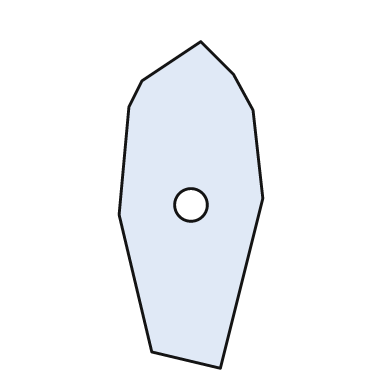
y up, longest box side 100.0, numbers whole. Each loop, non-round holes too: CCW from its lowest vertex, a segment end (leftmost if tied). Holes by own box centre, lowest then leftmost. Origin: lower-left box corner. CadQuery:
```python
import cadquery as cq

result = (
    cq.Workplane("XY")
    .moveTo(31.0, 0.0)
    .lineTo(44.0, 52.0)
    .lineTo(41.0, 79.0)
    .lineTo(35.0, 90.0)
    .lineTo(25.0, 100.0)
    .lineTo(7.0, 88.0)
    .lineTo(3.0, 80.0)
    .lineTo(0.0, 47.0)
    .lineTo(10.0, 5.0)
    .close()
    .moveTo(22.0, 50.0)
    .circle(5.0)
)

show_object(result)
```